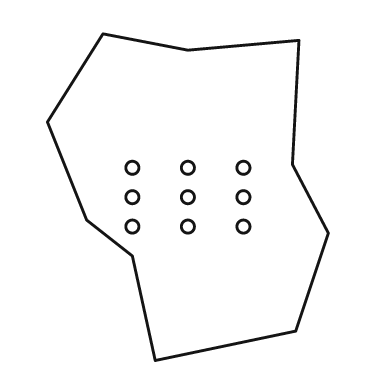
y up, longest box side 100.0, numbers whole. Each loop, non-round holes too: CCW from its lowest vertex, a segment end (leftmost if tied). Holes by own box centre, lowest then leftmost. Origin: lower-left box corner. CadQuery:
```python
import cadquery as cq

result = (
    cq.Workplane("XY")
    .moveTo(33.0, 0.0)
    .lineTo(76.0, 9.0)
    .lineTo(86.0, 39.0)
    .lineTo(75.0, 60.0)
    .lineTo(77.0, 98.0)
    .lineTo(43.0, 95.0)
    .lineTo(17.0, 100.0)
    .lineTo(0.0, 73.0)
    .lineTo(12.0, 43.0)
    .lineTo(26.0, 32.0)
    .close()
    .moveTo(26.0, 41.0)
    .circle(2.0)
    .moveTo(43.0, 41.0)
    .circle(2.0)
    .moveTo(60.0, 41.0)
    .circle(2.0)
    .moveTo(26.0, 50.0)
    .circle(2.0)
    .moveTo(43.0, 50.0)
    .circle(2.0)
    .moveTo(60.0, 50.0)
    .circle(2.0)
    .moveTo(26.0, 59.0)
    .circle(2.0)
    .moveTo(43.0, 59.0)
    .circle(2.0)
    .moveTo(60.0, 59.0)
    .circle(2.0)
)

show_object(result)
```